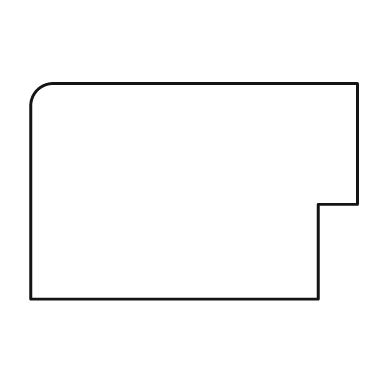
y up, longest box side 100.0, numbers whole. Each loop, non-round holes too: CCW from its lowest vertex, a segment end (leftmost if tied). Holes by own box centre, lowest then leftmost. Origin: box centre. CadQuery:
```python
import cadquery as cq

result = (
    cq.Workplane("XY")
    .moveTo(-50.0, -33.0)
    .lineTo(38.0, -33.0)
    .lineTo(38.0, -4.0)
    .lineTo(50.0, -4.0)
    .lineTo(50.0, 33.0)
    .lineTo(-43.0, 33.0)
    .threePointArc((-48.0, 31.0), (-50.0, 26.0))
    .close()
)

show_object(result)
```